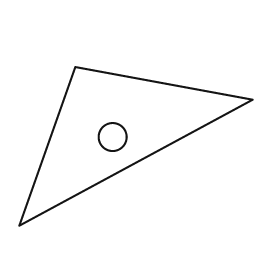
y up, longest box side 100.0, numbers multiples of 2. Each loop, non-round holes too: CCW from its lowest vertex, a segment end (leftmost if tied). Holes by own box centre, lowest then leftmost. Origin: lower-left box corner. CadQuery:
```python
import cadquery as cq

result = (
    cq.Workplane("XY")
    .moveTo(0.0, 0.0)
    .lineTo(100.0, 54.0)
    .lineTo(24.0, 68.0)
    .close()
    .moveTo(40.0, 38.0)
    .circle(6.0)
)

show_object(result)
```